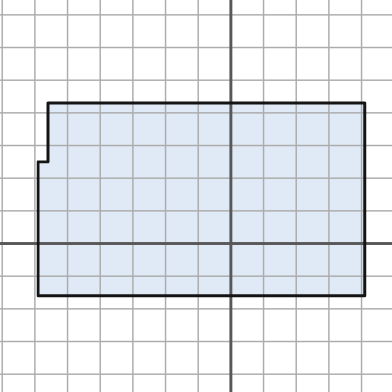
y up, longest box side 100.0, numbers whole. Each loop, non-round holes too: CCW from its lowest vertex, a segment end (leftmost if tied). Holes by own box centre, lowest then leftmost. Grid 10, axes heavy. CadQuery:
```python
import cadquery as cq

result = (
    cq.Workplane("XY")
    .moveTo(-59.0, -16.0)
    .lineTo(41.0, -16.0)
    .lineTo(41.0, 43.0)
    .lineTo(-56.0, 43.0)
    .lineTo(-56.0, 25.0)
    .lineTo(-59.0, 25.0)
    .close()
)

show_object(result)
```